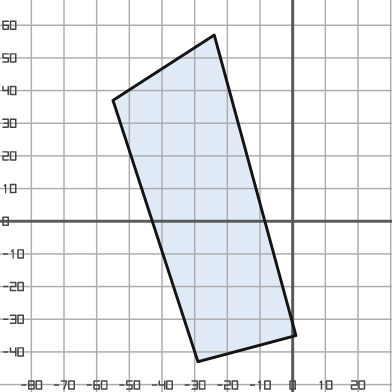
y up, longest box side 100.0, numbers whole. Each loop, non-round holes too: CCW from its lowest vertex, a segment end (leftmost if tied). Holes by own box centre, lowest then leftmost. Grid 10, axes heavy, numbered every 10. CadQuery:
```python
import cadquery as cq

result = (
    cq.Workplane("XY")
    .moveTo(-29.0, -43.0)
    .lineTo(1.0, -35.0)
    .lineTo(-24.0, 57.0)
    .lineTo(-55.0, 37.0)
    .close()
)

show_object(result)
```